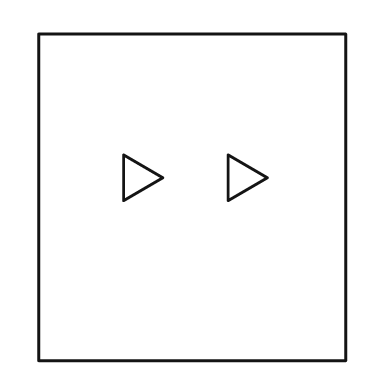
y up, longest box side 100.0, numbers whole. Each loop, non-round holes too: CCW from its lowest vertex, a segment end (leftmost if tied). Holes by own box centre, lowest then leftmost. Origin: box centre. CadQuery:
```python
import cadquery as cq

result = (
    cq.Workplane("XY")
    .moveTo(-47.0, -50.0)
    .lineTo(47.0, -50.0)
    .lineTo(47.0, 50.0)
    .lineTo(-47.0, 50.0)
    .close()
    .moveTo(-21.0, -1.0)
    .lineTo(-9.0, 6.0)
    .lineTo(-21.0, 13.0)
    .close()
    .moveTo(11.0, -1.0)
    .lineTo(23.0, 6.0)
    .lineTo(11.0, 13.0)
    .close()
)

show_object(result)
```